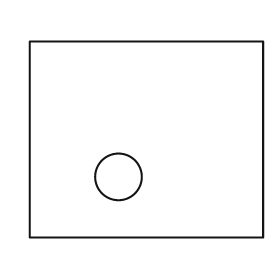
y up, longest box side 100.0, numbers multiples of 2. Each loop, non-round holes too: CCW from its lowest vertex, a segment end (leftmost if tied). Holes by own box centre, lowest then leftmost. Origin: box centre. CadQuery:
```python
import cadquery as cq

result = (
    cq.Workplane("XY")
    .moveTo(-50.0, -42.0)
    .lineTo(50.0, -42.0)
    .lineTo(50.0, 42.0)
    .lineTo(-50.0, 42.0)
    .close()
    .moveTo(-12.0, -16.0)
    .circle(10.0)
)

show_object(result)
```